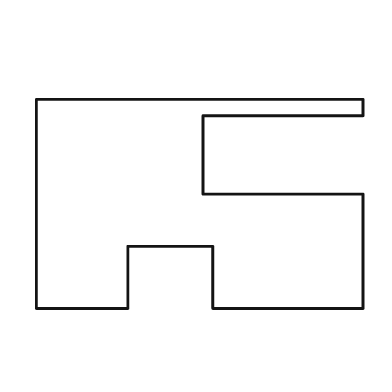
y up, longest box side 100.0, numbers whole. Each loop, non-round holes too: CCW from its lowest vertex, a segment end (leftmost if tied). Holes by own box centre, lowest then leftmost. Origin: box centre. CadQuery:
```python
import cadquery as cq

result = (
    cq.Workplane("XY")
    .moveTo(-50.0, -32.0)
    .lineTo(-22.0, -32.0)
    .lineTo(-22.0, -13.0)
    .lineTo(4.0, -13.0)
    .lineTo(4.0, -32.0)
    .lineTo(50.0, -32.0)
    .lineTo(50.0, 3.0)
    .lineTo(1.0, 3.0)
    .lineTo(1.0, 27.0)
    .lineTo(50.0, 27.0)
    .lineTo(50.0, 32.0)
    .lineTo(-50.0, 32.0)
    .close()
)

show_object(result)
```